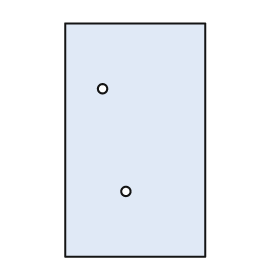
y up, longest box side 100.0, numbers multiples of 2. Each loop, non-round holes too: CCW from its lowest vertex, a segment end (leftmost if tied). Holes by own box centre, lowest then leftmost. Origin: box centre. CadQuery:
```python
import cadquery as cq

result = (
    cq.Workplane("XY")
    .moveTo(-30.0, -50.0)
    .lineTo(30.0, -50.0)
    .lineTo(30.0, 50.0)
    .lineTo(-30.0, 50.0)
    .close()
    .moveTo(-4.0, -22.0)
    .circle(2.0)
    .moveTo(-14.0, 22.0)
    .circle(2.0)
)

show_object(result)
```